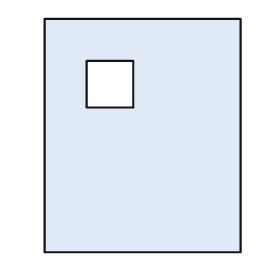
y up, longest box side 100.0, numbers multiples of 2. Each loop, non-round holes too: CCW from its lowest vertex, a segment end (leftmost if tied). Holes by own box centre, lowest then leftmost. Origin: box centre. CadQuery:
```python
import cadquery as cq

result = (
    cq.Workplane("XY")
    .moveTo(-42.0, -50.0)
    .lineTo(42.0, -50.0)
    .lineTo(42.0, 50.0)
    .lineTo(-42.0, 50.0)
    .close()
    .moveTo(-24.0, 12.0)
    .lineTo(-4.0, 12.0)
    .lineTo(-4.0, 32.0)
    .lineTo(-24.0, 32.0)
    .close()
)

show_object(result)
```